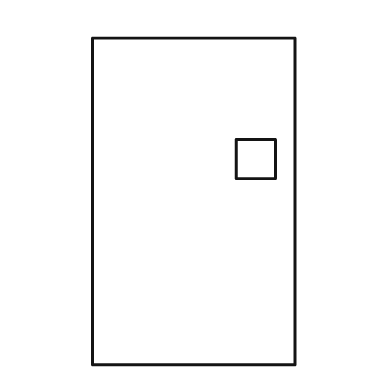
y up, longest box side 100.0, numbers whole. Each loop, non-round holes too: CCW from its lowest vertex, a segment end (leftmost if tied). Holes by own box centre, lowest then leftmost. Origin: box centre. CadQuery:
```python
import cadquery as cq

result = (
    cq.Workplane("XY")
    .moveTo(-31.0, -50.0)
    .lineTo(31.0, -50.0)
    .lineTo(31.0, 50.0)
    .lineTo(-31.0, 50.0)
    .close()
    .moveTo(13.0, 7.0)
    .lineTo(25.0, 7.0)
    .lineTo(25.0, 19.0)
    .lineTo(13.0, 19.0)
    .close()
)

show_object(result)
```